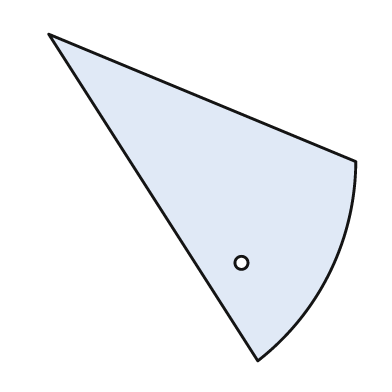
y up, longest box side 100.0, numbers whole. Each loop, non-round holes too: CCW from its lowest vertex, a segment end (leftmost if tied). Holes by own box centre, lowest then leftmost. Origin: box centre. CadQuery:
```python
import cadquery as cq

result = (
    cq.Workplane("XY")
    .moveTo(17.0, -50.0)
    .threePointArc((39.0, -23.0), (47.0, 11.0))
    .lineTo(-47.0, 50.0)
    .close()
    .moveTo(12.0, -20.0)
    .circle(2.0)
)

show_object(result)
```